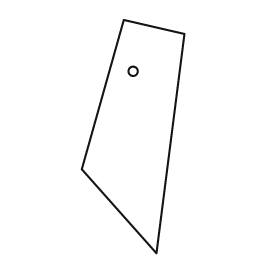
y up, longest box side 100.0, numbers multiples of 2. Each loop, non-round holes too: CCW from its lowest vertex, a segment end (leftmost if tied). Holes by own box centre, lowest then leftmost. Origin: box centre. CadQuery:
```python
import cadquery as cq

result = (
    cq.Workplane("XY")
    .moveTo(10.0, -50.0)
    .lineTo(22.0, 44.0)
    .lineTo(-4.0, 50.0)
    .lineTo(-22.0, -14.0)
    .close()
    .moveTo(0.0, 28.0)
    .circle(2.0)
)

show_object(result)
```